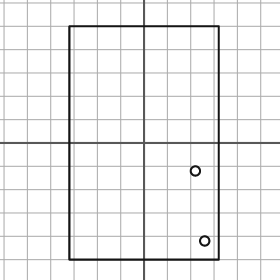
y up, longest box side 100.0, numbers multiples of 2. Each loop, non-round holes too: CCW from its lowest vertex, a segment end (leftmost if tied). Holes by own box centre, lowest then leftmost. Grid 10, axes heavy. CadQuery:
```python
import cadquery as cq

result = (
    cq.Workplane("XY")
    .moveTo(-32.0, -50.0)
    .lineTo(32.0, -50.0)
    .lineTo(32.0, 50.0)
    .lineTo(-32.0, 50.0)
    .close()
    .moveTo(26.0, -42.0)
    .circle(2.0)
    .moveTo(22.0, -12.0)
    .circle(2.0)
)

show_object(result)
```